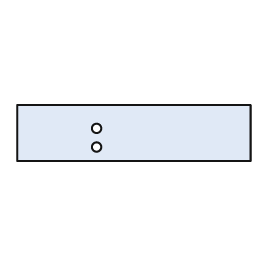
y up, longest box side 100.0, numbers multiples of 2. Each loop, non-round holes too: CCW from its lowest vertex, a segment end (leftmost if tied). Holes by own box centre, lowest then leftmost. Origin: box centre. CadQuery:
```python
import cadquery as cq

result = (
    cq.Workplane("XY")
    .moveTo(-50.0, -12.0)
    .lineTo(50.0, -12.0)
    .lineTo(50.0, 12.0)
    .lineTo(-50.0, 12.0)
    .close()
    .moveTo(-16.0, -6.0)
    .circle(2.0)
    .moveTo(-16.0, 2.0)
    .circle(2.0)
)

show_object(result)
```